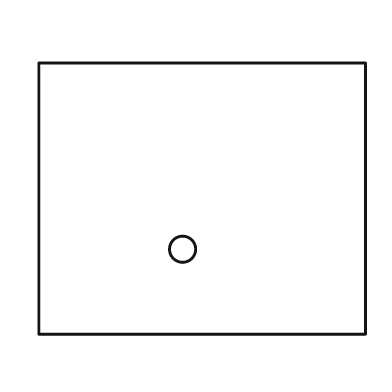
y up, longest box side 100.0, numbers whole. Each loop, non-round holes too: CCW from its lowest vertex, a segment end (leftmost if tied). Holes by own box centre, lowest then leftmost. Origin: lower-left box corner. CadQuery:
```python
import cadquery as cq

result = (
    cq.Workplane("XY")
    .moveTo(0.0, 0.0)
    .lineTo(100.0, 0.0)
    .lineTo(100.0, 83.0)
    .lineTo(0.0, 83.0)
    .close()
    .moveTo(44.0, 26.0)
    .circle(4.0)
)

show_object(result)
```